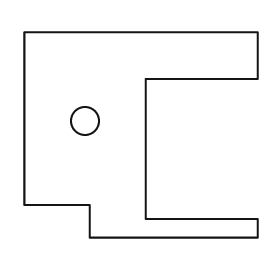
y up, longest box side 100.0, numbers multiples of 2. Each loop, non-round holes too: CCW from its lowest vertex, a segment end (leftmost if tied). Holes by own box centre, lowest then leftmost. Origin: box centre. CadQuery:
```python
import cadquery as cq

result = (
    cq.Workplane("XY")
    .moveTo(-22.0, -44.0)
    .lineTo(50.0, -44.0)
    .lineTo(50.0, -36.0)
    .lineTo(2.0, -36.0)
    .lineTo(2.0, 24.0)
    .lineTo(50.0, 24.0)
    .lineTo(50.0, 44.0)
    .lineTo(-50.0, 44.0)
    .lineTo(-50.0, -30.0)
    .lineTo(-22.0, -30.0)
    .close()
    .moveTo(-24.0, 6.0)
    .circle(6.0)
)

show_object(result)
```